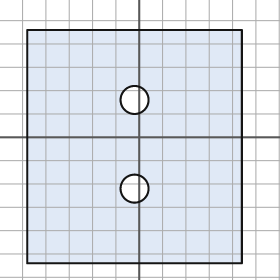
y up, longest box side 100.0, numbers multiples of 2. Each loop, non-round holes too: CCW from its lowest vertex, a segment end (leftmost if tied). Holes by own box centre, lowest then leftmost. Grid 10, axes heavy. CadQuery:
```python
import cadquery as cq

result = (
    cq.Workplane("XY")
    .moveTo(-48.0, -54.0)
    .lineTo(44.0, -54.0)
    .lineTo(44.0, 46.0)
    .lineTo(-48.0, 46.0)
    .close()
    .moveTo(-2.0, -22.0)
    .circle(6.0)
    .moveTo(-2.0, 16.0)
    .circle(6.0)
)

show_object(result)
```